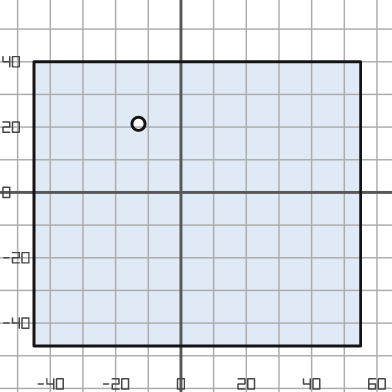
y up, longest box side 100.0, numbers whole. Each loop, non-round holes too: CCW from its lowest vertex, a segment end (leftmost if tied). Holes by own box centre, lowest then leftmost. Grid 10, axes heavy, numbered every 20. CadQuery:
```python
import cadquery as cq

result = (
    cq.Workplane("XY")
    .moveTo(-45.0, -47.0)
    .lineTo(55.0, -47.0)
    .lineTo(55.0, 40.0)
    .lineTo(-45.0, 40.0)
    .close()
    .moveTo(-13.0, 21.0)
    .circle(2.0)
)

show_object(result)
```